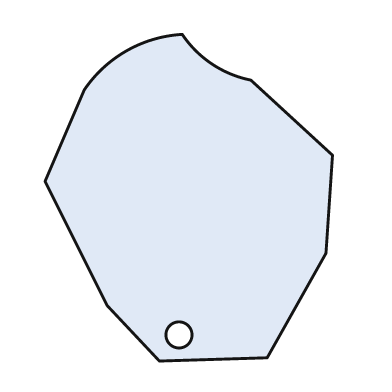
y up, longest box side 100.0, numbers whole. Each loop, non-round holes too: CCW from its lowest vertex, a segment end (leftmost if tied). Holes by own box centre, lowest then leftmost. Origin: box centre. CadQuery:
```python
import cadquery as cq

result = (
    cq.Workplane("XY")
    .moveTo(-9.0, -50.0)
    .lineTo(24.0, -49.0)
    .lineTo(42.0, -17.0)
    .lineTo(44.0, 13.0)
    .lineTo(19.0, 36.0)
    .threePointArc((7.0, 41.0), (-2.0, 50.0))
    .threePointArc((-19.0, 45.0), (-32.0, 33.0))
    .lineTo(-44.0, 5.0)
    .lineTo(-25.0, -33.0)
    .close()
    .moveTo(-3.0, -42.0)
    .circle(4.0)
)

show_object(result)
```